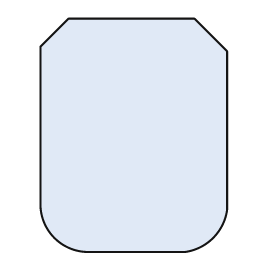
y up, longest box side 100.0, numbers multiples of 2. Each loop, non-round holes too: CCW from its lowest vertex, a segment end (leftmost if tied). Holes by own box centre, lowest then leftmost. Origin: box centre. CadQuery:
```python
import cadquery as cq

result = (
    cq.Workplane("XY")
    .moveTo(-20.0, -50.0)
    .lineTo(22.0, -50.0)
    .threePointArc((34.0, -44.0), (40.0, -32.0))
    .lineTo(40.0, 36.0)
    .lineTo(26.0, 50.0)
    .lineTo(-28.0, 50.0)
    .lineTo(-40.0, 38.0)
    .lineTo(-40.0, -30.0)
    .threePointArc((-34.0, -44.0), (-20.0, -50.0))
    .close()
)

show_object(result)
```